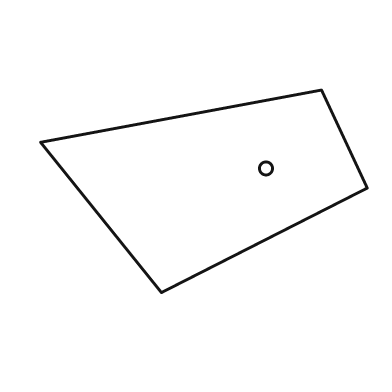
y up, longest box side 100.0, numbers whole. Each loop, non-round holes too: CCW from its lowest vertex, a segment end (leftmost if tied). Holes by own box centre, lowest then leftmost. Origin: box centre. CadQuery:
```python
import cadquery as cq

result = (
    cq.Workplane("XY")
    .moveTo(-13.0, -31.0)
    .lineTo(50.0, 1.0)
    .lineTo(36.0, 31.0)
    .lineTo(-50.0, 15.0)
    .close()
    .moveTo(19.0, 7.0)
    .circle(2.0)
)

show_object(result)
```